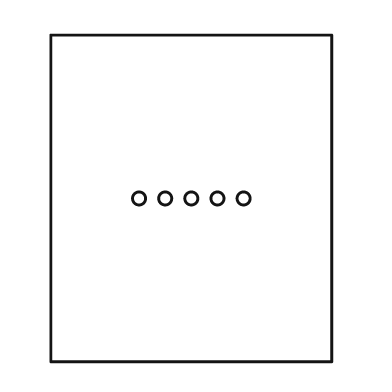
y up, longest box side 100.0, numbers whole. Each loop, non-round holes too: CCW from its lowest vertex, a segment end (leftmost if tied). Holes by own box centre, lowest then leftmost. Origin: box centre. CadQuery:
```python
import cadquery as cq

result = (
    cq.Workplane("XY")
    .moveTo(-43.0, -50.0)
    .lineTo(43.0, -50.0)
    .lineTo(43.0, 50.0)
    .lineTo(-43.0, 50.0)
    .close()
    .moveTo(-16.0, 0.0)
    .circle(2.0)
    .moveTo(-8.0, 0.0)
    .circle(2.0)
    .moveTo(0.0, 0.0)
    .circle(2.0)
    .moveTo(8.0, 0.0)
    .circle(2.0)
    .moveTo(16.0, 0.0)
    .circle(2.0)
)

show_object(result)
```